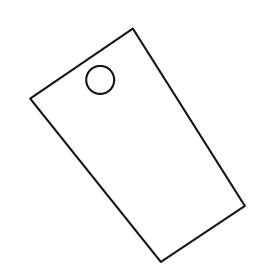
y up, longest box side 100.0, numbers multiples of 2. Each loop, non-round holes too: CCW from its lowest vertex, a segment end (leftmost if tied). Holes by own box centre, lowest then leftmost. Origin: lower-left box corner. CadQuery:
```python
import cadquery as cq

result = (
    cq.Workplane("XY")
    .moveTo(56.0, 0.0)
    .lineTo(92.0, 24.0)
    .lineTo(44.0, 100.0)
    .lineTo(0.0, 70.0)
    .close()
    .moveTo(30.0, 78.0)
    .circle(6.0)
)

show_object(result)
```